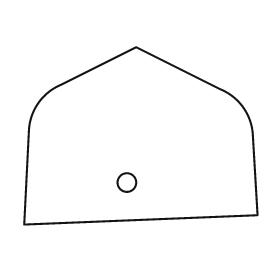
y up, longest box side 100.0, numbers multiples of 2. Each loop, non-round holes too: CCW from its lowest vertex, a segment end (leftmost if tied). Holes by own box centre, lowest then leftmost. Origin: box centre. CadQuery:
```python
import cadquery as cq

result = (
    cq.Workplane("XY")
    .moveTo(-50.0, -38.0)
    .lineTo(50.0, -34.0)
    .lineTo(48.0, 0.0)
    .threePointArc((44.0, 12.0), (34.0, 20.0))
    .lineTo(-2.0, 38.0)
    .lineTo(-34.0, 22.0)
    .threePointArc((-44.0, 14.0), (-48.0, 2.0))
    .close()
    .moveTo(-6.0, -20.0)
    .circle(4.0)
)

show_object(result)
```